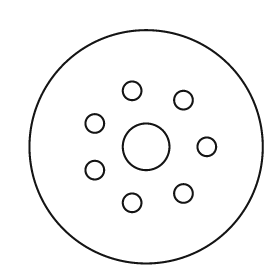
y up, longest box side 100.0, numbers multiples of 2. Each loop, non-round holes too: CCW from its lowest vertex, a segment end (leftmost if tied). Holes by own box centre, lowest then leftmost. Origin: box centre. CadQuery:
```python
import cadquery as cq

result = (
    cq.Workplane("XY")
    .moveTo(0.0, 0.0)
    .circle(50.0)
    .moveTo(-6.0, -24.0)
    .circle(4.0)
    .moveTo(16.0, -20.0)
    .circle(4.0)
    .moveTo(-22.0, -10.0)
    .circle(4.0)
    .moveTo(0.0, 0.0)
    .circle(10.0)
    .moveTo(26.0, 0.0)
    .circle(4.0)
    .moveTo(-22.0, 10.0)
    .circle(4.0)
    .moveTo(16.0, 20.0)
    .circle(4.0)
    .moveTo(-6.0, 24.0)
    .circle(4.0)
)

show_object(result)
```